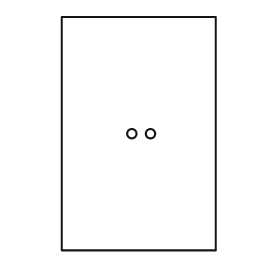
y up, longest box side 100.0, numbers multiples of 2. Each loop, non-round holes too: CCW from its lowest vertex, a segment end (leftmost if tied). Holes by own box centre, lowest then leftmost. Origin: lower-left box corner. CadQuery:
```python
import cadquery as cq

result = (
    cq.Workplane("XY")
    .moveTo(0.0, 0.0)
    .lineTo(66.0, 0.0)
    .lineTo(66.0, 100.0)
    .lineTo(0.0, 100.0)
    .close()
    .moveTo(30.0, 50.0)
    .circle(2.0)
    .moveTo(38.0, 50.0)
    .circle(2.0)
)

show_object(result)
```